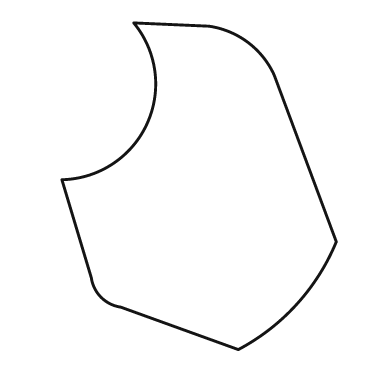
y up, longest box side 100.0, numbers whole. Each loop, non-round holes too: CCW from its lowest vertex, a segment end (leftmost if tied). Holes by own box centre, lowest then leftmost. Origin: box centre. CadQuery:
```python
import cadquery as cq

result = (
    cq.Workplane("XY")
    .moveTo(12.0, -50.0)
    .threePointArc((30.0, -36.0), (42.0, -17.0))
    .lineTo(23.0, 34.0)
    .threePointArc((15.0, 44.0), (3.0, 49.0))
    .lineTo(-20.0, 50.0)
    .threePointArc((-16.0, 19.0), (-42.0, 2.0))
    .lineTo(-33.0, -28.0)
    .threePointArc((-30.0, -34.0), (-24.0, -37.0))
    .close()
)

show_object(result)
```